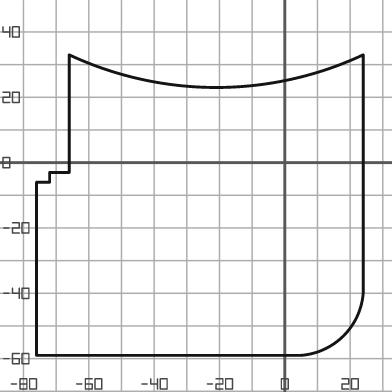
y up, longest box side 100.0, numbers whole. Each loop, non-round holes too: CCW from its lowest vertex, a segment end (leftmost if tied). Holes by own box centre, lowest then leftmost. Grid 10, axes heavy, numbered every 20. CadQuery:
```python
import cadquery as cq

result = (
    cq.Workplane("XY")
    .moveTo(-76.0, -59.0)
    .lineTo(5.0, -59.0)
    .threePointArc((18.0, -53.0), (24.0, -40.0))
    .lineTo(24.0, 33.0)
    .threePointArc((-21.0, 23.0), (-66.0, 33.0))
    .lineTo(-66.0, -3.0)
    .lineTo(-72.0, -3.0)
    .lineTo(-72.0, -6.0)
    .lineTo(-76.0, -6.0)
    .close()
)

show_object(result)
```